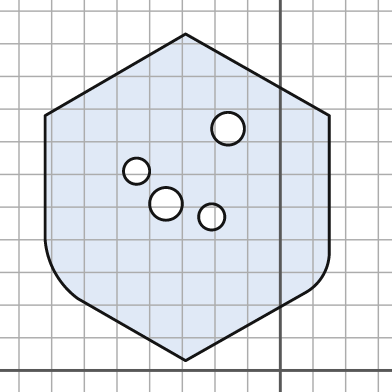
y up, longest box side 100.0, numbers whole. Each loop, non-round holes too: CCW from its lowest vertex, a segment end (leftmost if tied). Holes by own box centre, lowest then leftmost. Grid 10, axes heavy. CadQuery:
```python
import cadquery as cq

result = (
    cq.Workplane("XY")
    .moveTo(-29.0, 3.0)
    .lineTo(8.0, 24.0)
    .threePointArc((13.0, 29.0), (15.0, 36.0))
    .lineTo(15.0, 78.0)
    .lineTo(-29.0, 103.0)
    .lineTo(-72.0, 78.0)
    .lineTo(-72.0, 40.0)
    .threePointArc((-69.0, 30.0), (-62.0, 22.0))
    .close()
    .moveTo(-21.0, 47.0)
    .circle(4.0)
    .moveTo(-35.0, 51.0)
    .circle(5.0)
    .moveTo(-44.0, 61.0)
    .circle(4.0)
    .moveTo(-16.0, 74.0)
    .circle(5.0)
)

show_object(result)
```